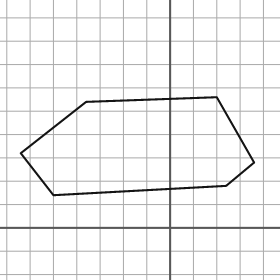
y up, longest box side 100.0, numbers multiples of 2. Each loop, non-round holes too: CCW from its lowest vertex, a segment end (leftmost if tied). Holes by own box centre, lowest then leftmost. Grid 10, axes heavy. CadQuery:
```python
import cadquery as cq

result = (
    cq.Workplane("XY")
    .moveTo(-50.0, 14.0)
    .lineTo(24.0, 18.0)
    .lineTo(36.0, 28.0)
    .lineTo(20.0, 56.0)
    .lineTo(-36.0, 54.0)
    .lineTo(-64.0, 32.0)
    .close()
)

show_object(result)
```